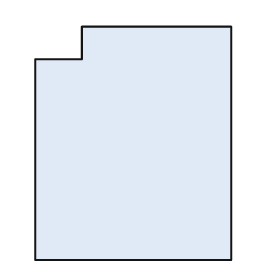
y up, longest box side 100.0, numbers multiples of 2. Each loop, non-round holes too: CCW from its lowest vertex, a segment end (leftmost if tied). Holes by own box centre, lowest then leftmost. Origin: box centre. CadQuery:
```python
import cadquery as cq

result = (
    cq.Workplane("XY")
    .moveTo(-42.0, -50.0)
    .lineTo(42.0, -50.0)
    .lineTo(42.0, 50.0)
    .lineTo(-22.0, 50.0)
    .lineTo(-22.0, 36.0)
    .lineTo(-42.0, 36.0)
    .close()
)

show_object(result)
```